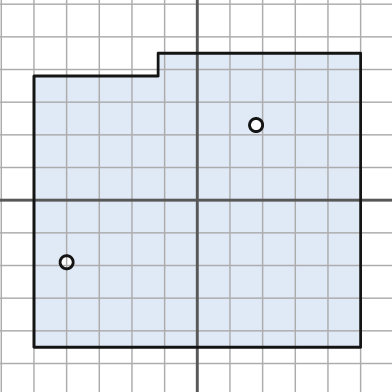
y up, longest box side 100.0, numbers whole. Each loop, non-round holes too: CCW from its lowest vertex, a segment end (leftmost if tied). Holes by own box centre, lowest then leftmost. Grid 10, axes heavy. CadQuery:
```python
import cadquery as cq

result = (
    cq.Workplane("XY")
    .moveTo(-50.0, -45.0)
    .lineTo(50.0, -45.0)
    .lineTo(50.0, 45.0)
    .lineTo(-12.0, 45.0)
    .lineTo(-12.0, 38.0)
    .lineTo(-50.0, 38.0)
    .close()
    .moveTo(-40.0, -19.0)
    .circle(2.0)
    .moveTo(18.0, 23.0)
    .circle(2.0)
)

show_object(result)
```